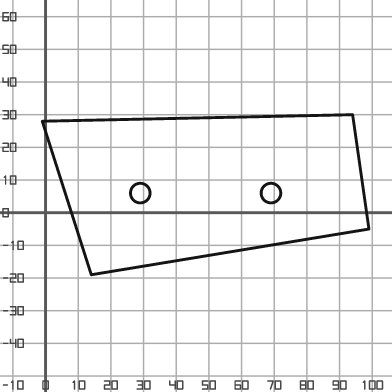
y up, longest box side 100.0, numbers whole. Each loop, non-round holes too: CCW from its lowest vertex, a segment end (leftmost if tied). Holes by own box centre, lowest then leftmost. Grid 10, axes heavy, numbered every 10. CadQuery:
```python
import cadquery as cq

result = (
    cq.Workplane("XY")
    .moveTo(14.0, -19.0)
    .lineTo(99.0, -5.0)
    .lineTo(94.0, 30.0)
    .lineTo(-1.0, 28.0)
    .close()
    .moveTo(29.0, 6.0)
    .circle(3.0)
    .moveTo(69.0, 6.0)
    .circle(3.0)
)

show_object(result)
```